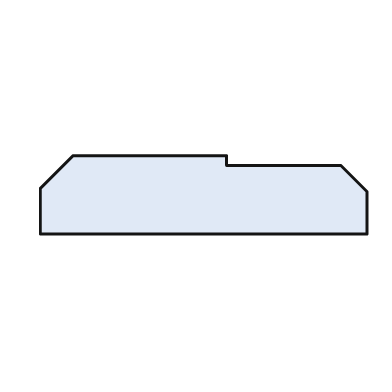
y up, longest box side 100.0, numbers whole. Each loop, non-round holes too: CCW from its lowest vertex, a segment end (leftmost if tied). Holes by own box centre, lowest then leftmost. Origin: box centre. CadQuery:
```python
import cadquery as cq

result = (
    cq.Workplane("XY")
    .moveTo(-50.0, -12.0)
    .lineTo(50.0, -12.0)
    .lineTo(50.0, 1.0)
    .lineTo(42.0, 9.0)
    .lineTo(7.0, 9.0)
    .lineTo(7.0, 12.0)
    .lineTo(-40.0, 12.0)
    .lineTo(-50.0, 2.0)
    .close()
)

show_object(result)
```